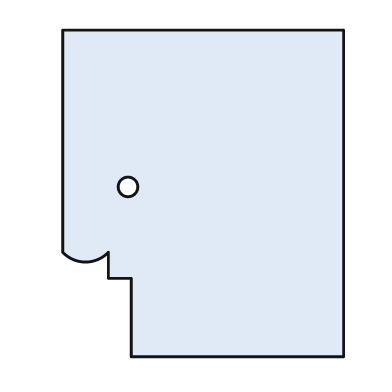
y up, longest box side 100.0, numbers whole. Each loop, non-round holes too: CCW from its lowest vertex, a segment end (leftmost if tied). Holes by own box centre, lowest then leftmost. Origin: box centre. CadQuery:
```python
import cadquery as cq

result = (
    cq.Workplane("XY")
    .moveTo(-22.0, -50.0)
    .lineTo(43.0, -50.0)
    .lineTo(43.0, 50.0)
    .lineTo(-43.0, 50.0)
    .lineTo(-43.0, -18.0)
    .threePointArc((-36.0, -21.0), (-29.0, -18.0))
    .lineTo(-29.0, -26.0)
    .lineTo(-22.0, -26.0)
    .close()
    .moveTo(-23.0, 2.0)
    .circle(3.0)
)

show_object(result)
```